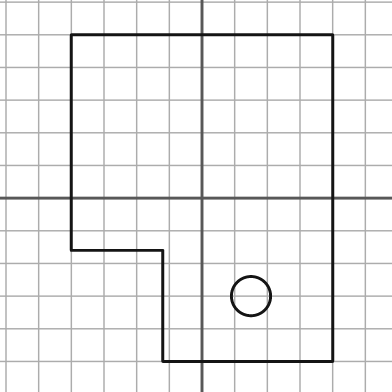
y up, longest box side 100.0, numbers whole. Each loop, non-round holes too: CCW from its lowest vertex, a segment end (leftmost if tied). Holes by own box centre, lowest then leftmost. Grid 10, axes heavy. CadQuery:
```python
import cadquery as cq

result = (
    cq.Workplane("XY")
    .moveTo(-12.0, -50.0)
    .lineTo(40.0, -50.0)
    .lineTo(40.0, 50.0)
    .lineTo(-40.0, 50.0)
    .lineTo(-40.0, -16.0)
    .lineTo(-12.0, -16.0)
    .close()
    .moveTo(15.0, -30.0)
    .circle(6.0)
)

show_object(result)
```